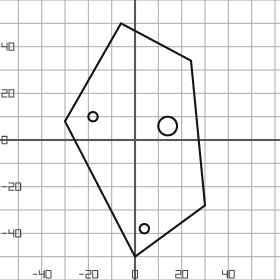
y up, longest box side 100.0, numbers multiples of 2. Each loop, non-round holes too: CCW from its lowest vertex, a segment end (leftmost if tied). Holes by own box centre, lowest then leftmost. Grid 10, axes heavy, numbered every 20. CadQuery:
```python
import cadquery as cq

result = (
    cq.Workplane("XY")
    .moveTo(0.0, -50.0)
    .lineTo(30.0, -28.0)
    .lineTo(24.0, 34.0)
    .lineTo(-6.0, 50.0)
    .lineTo(-30.0, 8.0)
    .close()
    .moveTo(4.0, -38.0)
    .circle(2.0)
    .moveTo(14.0, 6.0)
    .circle(4.0)
    .moveTo(-18.0, 10.0)
    .circle(2.0)
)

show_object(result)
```